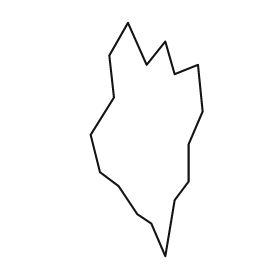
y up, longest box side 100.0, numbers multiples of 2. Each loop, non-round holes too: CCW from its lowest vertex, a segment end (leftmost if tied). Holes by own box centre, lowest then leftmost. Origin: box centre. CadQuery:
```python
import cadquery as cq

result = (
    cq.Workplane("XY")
    .moveTo(8.0, -50.0)
    .lineTo(12.0, -26.0)
    .lineTo(18.0, -18.0)
    .lineTo(18.0, -2.0)
    .lineTo(24.0, 12.0)
    .lineTo(22.0, 32.0)
    .lineTo(12.0, 28.0)
    .lineTo(8.0, 42.0)
    .lineTo(0.0, 32.0)
    .lineTo(-8.0, 50.0)
    .lineTo(-16.0, 36.0)
    .lineTo(-14.0, 18.0)
    .lineTo(-24.0, 2.0)
    .lineTo(-20.0, -14.0)
    .lineTo(-12.0, -20.0)
    .lineTo(-4.0, -32.0)
    .lineTo(2.0, -36.0)
    .close()
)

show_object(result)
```